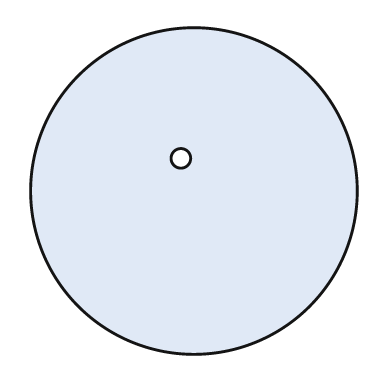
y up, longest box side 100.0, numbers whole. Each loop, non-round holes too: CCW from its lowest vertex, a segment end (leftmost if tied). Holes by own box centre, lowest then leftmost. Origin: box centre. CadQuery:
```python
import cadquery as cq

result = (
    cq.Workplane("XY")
    .moveTo(0.0, 0.0)
    .circle(50.0)
    .moveTo(-4.0, 10.0)
    .circle(3.0)
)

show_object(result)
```